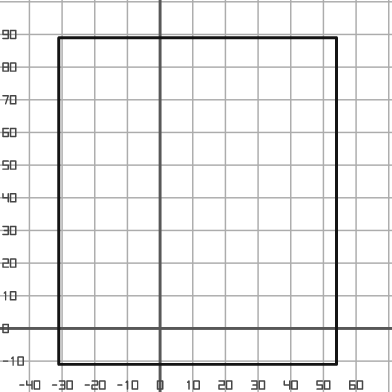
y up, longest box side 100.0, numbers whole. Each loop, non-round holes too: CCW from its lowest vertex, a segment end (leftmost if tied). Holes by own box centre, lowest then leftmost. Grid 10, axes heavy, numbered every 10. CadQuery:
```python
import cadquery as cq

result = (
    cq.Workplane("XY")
    .moveTo(-31.0, -11.0)
    .lineTo(54.0, -11.0)
    .lineTo(54.0, 89.0)
    .lineTo(-31.0, 89.0)
    .close()
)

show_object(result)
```